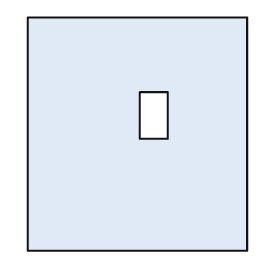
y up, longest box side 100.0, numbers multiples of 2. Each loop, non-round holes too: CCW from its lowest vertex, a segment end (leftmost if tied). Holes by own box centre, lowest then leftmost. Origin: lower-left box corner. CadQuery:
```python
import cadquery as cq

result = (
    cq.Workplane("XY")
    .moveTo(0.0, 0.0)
    .lineTo(94.0, 0.0)
    .lineTo(94.0, 100.0)
    .lineTo(0.0, 100.0)
    .close()
    .moveTo(48.0, 48.0)
    .lineTo(60.0, 48.0)
    .lineTo(60.0, 68.0)
    .lineTo(48.0, 68.0)
    .close()
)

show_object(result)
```